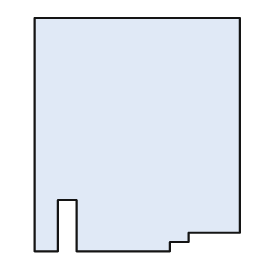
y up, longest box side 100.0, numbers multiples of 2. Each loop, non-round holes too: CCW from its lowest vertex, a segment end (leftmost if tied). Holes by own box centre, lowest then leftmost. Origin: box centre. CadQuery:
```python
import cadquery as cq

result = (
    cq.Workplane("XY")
    .moveTo(-44.0, -50.0)
    .lineTo(-34.0, -50.0)
    .lineTo(-34.0, -28.0)
    .lineTo(-26.0, -28.0)
    .lineTo(-26.0, -50.0)
    .lineTo(14.0, -50.0)
    .lineTo(14.0, -46.0)
    .lineTo(22.0, -46.0)
    .lineTo(22.0, -42.0)
    .lineTo(44.0, -42.0)
    .lineTo(44.0, 50.0)
    .lineTo(-44.0, 50.0)
    .close()
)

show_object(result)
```